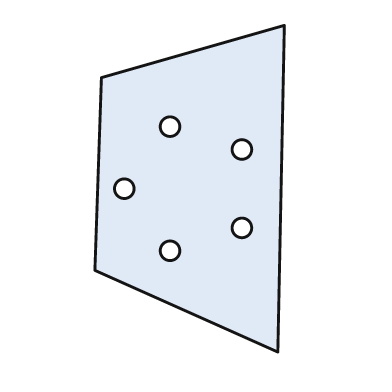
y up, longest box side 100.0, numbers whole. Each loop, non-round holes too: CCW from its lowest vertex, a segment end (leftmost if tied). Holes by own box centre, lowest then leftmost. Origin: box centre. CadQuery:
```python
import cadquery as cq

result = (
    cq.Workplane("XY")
    .moveTo(27.0, -50.0)
    .lineTo(29.0, 50.0)
    .lineTo(-27.0, 34.0)
    .lineTo(-29.0, -25.0)
    .close()
    .moveTo(-6.0, -19.0)
    .circle(3.0)
    .moveTo(16.0, -12.0)
    .circle(3.0)
    .moveTo(-20.0, 0.0)
    .circle(3.0)
    .moveTo(16.0, 12.0)
    .circle(3.0)
    .moveTo(-6.0, 19.0)
    .circle(3.0)
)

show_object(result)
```